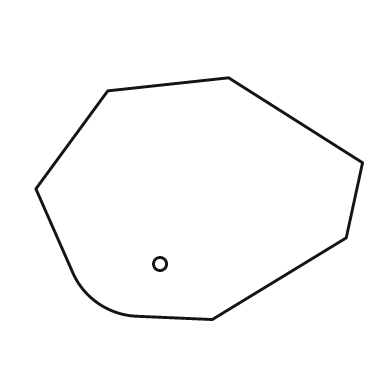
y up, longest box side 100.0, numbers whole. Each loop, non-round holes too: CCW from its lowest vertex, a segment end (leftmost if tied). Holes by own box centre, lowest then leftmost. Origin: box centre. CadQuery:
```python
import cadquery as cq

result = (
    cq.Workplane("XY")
    .moveTo(4.0, -37.0)
    .lineTo(45.0, -12.0)
    .lineTo(50.0, 11.0)
    .lineTo(9.0, 37.0)
    .lineTo(-28.0, 33.0)
    .lineTo(-50.0, 3.0)
    .lineTo(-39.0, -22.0)
    .threePointArc((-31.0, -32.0), (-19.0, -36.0))
    .close()
    .moveTo(-12.0, -20.0)
    .circle(2.0)
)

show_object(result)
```